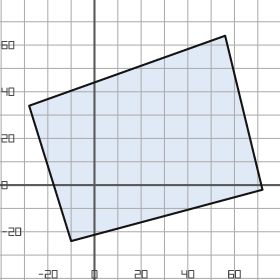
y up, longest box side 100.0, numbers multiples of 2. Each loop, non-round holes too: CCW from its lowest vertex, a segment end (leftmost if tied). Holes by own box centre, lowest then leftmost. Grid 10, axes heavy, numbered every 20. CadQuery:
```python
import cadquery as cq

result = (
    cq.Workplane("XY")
    .moveTo(-10.0, -24.0)
    .lineTo(72.0, -2.0)
    .lineTo(56.0, 64.0)
    .lineTo(-28.0, 34.0)
    .close()
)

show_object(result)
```